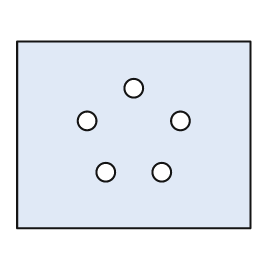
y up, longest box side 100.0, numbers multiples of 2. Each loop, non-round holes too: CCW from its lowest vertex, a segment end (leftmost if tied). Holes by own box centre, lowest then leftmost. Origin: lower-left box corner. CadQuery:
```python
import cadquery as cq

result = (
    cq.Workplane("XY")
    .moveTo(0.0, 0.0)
    .lineTo(100.0, 0.0)
    .lineTo(100.0, 80.0)
    .lineTo(0.0, 80.0)
    .close()
    .moveTo(38.0, 24.0)
    .circle(4.0)
    .moveTo(62.0, 24.0)
    .circle(4.0)
    .moveTo(30.0, 46.0)
    .circle(4.0)
    .moveTo(70.0, 46.0)
    .circle(4.0)
    .moveTo(50.0, 60.0)
    .circle(4.0)
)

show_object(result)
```